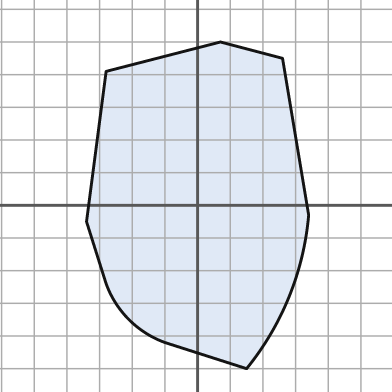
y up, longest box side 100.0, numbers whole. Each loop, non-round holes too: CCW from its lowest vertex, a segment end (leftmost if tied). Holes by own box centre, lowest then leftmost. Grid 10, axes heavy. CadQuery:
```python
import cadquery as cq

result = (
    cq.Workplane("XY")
    .moveTo(15.0, -50.0)
    .threePointArc((28.0, -28.0), (34.0, -3.0))
    .lineTo(26.0, 45.0)
    .lineTo(7.0, 50.0)
    .lineTo(-28.0, 41.0)
    .lineTo(-34.0, -5.0)
    .lineTo(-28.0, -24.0)
    .threePointArc((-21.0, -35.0), (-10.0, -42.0))
    .close()
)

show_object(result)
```